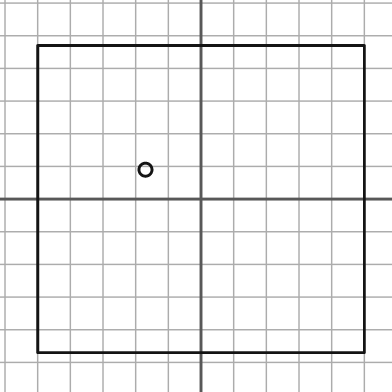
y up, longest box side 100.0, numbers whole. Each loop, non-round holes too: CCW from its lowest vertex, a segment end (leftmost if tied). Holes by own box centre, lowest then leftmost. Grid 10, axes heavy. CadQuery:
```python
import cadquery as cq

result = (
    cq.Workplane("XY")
    .moveTo(-50.0, -47.0)
    .lineTo(50.0, -47.0)
    .lineTo(50.0, 47.0)
    .lineTo(-50.0, 47.0)
    .close()
    .moveTo(-17.0, 9.0)
    .circle(2.0)
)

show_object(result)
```